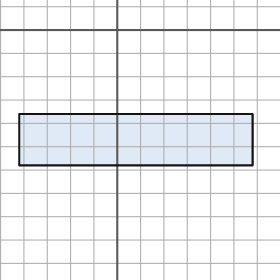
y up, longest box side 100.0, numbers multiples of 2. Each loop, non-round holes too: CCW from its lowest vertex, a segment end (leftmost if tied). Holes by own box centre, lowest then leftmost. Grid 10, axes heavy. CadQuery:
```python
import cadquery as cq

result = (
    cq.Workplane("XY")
    .moveTo(-42.0, -58.0)
    .lineTo(58.0, -58.0)
    .lineTo(58.0, -36.0)
    .lineTo(-42.0, -36.0)
    .close()
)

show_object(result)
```